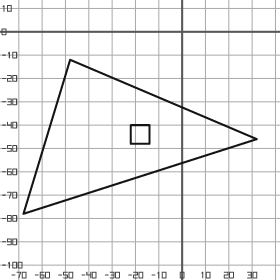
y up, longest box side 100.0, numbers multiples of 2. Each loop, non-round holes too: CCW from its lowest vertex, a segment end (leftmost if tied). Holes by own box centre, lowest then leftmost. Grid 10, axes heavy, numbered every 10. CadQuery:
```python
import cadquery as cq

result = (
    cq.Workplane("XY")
    .moveTo(-68.0, -78.0)
    .lineTo(32.0, -46.0)
    .lineTo(-48.0, -12.0)
    .close()
    .moveTo(-22.0, -48.0)
    .lineTo(-14.0, -48.0)
    .lineTo(-14.0, -40.0)
    .lineTo(-22.0, -40.0)
    .close()
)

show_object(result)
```